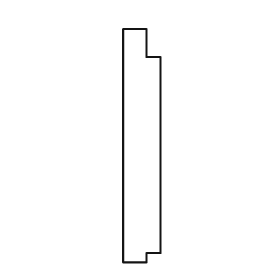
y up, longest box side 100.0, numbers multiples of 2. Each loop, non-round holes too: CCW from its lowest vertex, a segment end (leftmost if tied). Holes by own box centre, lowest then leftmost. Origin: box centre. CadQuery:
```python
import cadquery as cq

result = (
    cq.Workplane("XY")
    .moveTo(-8.0, -50.0)
    .lineTo(2.0, -50.0)
    .lineTo(2.0, -46.0)
    .lineTo(8.0, -46.0)
    .lineTo(8.0, 38.0)
    .lineTo(2.0, 38.0)
    .lineTo(2.0, 50.0)
    .lineTo(-8.0, 50.0)
    .close()
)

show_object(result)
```